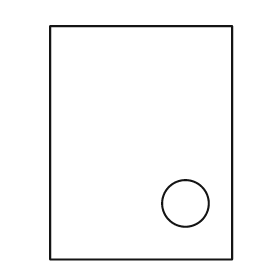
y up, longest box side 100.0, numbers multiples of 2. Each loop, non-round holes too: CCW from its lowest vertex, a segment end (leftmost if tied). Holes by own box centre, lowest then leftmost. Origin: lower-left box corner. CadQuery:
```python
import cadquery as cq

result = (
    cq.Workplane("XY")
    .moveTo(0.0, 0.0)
    .lineTo(78.0, 0.0)
    .lineTo(78.0, 100.0)
    .lineTo(0.0, 100.0)
    .close()
    .moveTo(58.0, 24.0)
    .circle(10.0)
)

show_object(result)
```